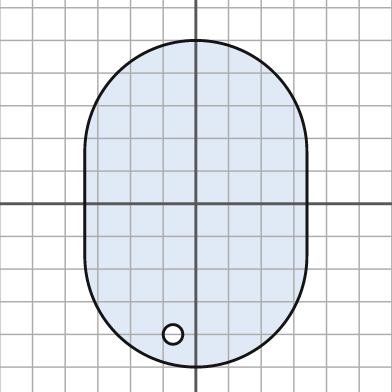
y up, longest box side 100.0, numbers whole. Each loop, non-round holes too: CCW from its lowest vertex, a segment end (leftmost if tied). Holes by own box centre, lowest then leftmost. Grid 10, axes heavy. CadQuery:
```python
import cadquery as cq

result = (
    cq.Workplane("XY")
    .moveTo(-34.0, -16.0)
    .threePointArc((0.0, -50.0), (34.0, -16.0))
    .lineTo(34.0, 16.0)
    .threePointArc((0.0, 50.0), (-34.0, 16.0))
    .close()
    .moveTo(-7.0, -40.0)
    .circle(3.0)
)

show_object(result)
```